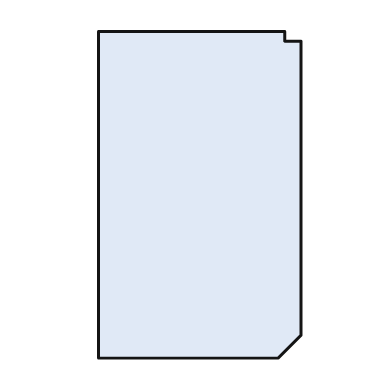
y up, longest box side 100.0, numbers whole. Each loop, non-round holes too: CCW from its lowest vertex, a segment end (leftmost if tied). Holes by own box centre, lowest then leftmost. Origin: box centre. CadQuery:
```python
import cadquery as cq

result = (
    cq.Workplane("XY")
    .moveTo(-31.0, -50.0)
    .lineTo(24.0, -50.0)
    .lineTo(31.0, -43.0)
    .lineTo(31.0, 47.0)
    .lineTo(26.0, 47.0)
    .lineTo(26.0, 50.0)
    .lineTo(-31.0, 50.0)
    .close()
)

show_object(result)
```